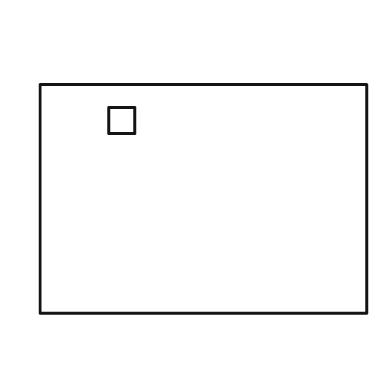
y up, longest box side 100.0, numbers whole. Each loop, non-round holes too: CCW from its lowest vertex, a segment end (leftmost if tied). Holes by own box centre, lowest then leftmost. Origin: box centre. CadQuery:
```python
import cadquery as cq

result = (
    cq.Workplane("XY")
    .moveTo(-50.0, -35.0)
    .lineTo(50.0, -35.0)
    .lineTo(50.0, 35.0)
    .lineTo(-50.0, 35.0)
    .close()
    .moveTo(-29.0, 20.0)
    .lineTo(-21.0, 20.0)
    .lineTo(-21.0, 28.0)
    .lineTo(-29.0, 28.0)
    .close()
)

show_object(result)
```